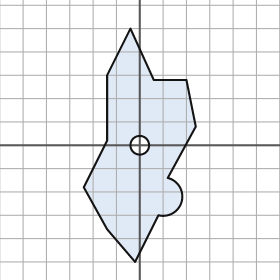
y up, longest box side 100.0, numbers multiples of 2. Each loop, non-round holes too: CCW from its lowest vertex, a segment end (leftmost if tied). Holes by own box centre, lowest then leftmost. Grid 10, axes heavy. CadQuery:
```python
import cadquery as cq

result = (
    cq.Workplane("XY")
    .moveTo(-2.0, -50.0)
    .lineTo(8.0, -30.0)
    .threePointArc((18.0, -24.0), (12.0, -14.0))
    .lineTo(24.0, 8.0)
    .lineTo(20.0, 28.0)
    .lineTo(6.0, 28.0)
    .lineTo(-4.0, 50.0)
    .lineTo(-14.0, 30.0)
    .lineTo(-14.0, 2.0)
    .lineTo(-24.0, -18.0)
    .lineTo(-14.0, -36.0)
    .close()
    .moveTo(0.0, 0.0)
    .circle(4.0)
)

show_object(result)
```